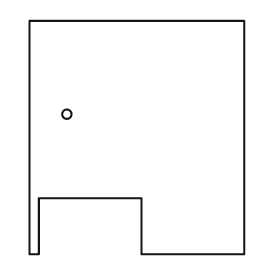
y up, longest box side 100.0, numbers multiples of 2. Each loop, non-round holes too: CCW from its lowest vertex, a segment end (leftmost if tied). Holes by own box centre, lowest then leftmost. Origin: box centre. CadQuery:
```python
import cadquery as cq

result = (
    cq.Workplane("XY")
    .moveTo(-46.0, -50.0)
    .lineTo(-42.0, -50.0)
    .lineTo(-42.0, -26.0)
    .lineTo(2.0, -26.0)
    .lineTo(2.0, -50.0)
    .lineTo(46.0, -50.0)
    .lineTo(46.0, 50.0)
    .lineTo(-46.0, 50.0)
    .close()
    .moveTo(-30.0, 10.0)
    .circle(2.0)
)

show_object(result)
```